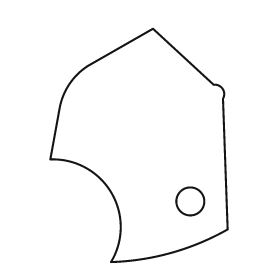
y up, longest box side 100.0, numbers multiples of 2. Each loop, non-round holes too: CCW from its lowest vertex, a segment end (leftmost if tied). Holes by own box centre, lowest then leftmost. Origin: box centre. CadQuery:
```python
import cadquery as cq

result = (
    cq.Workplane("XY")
    .moveTo(-12.0, -50.0)
    .threePointArc((14.0, -46.0), (38.0, -36.0))
    .lineTo(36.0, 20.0)
    .threePointArc((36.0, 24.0), (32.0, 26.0))
    .lineTo(6.0, 50.0)
    .lineTo(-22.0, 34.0)
    .threePointArc((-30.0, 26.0), (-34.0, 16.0))
    .lineTo(-38.0, -6.0)
    .threePointArc((-12.0, -20.0), (-12.0, -50.0))
    .close()
    .moveTo(22.0, -24.0)
    .circle(6.0)
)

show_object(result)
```